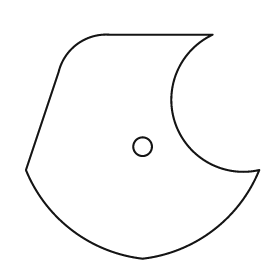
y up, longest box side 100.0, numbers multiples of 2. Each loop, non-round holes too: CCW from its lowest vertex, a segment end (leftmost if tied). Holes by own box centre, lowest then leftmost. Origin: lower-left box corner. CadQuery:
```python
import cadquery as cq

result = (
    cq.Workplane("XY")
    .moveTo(50.0, 0.0)
    .threePointArc((80.0, 12.0), (100.0, 38.0))
    .threePointArc((64.0, 58.0), (80.0, 96.0))
    .lineTo(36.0, 96.0)
    .threePointArc((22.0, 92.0), (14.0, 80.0))
    .lineTo(0.0, 38.0)
    .threePointArc((20.0, 12.0), (50.0, 0.0))
    .close()
    .moveTo(50.0, 48.0)
    .circle(4.0)
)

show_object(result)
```